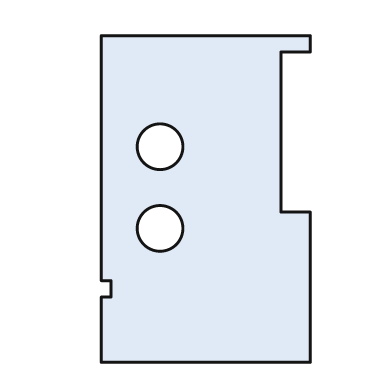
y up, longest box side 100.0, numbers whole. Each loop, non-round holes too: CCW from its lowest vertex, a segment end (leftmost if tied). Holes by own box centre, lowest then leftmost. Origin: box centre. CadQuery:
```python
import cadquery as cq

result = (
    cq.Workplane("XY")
    .moveTo(-32.0, -50.0)
    .lineTo(32.0, -50.0)
    .lineTo(32.0, -4.0)
    .lineTo(23.0, -4.0)
    .lineTo(23.0, 45.0)
    .lineTo(32.0, 45.0)
    .lineTo(32.0, 50.0)
    .lineTo(-32.0, 50.0)
    .lineTo(-32.0, -25.0)
    .lineTo(-29.0, -25.0)
    .lineTo(-29.0, -30.0)
    .lineTo(-32.0, -30.0)
    .close()
    .moveTo(-14.0, -9.0)
    .circle(7.0)
    .moveTo(-14.0, 16.0)
    .circle(7.0)
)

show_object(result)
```